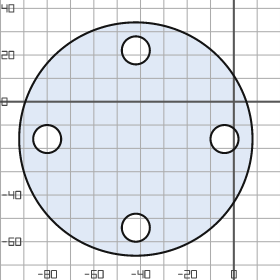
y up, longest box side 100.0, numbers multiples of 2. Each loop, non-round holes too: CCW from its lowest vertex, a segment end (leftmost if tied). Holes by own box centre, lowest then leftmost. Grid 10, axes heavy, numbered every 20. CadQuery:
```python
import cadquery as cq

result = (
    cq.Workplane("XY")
    .moveTo(-42.0, -16.0)
    .circle(50.0)
    .moveTo(-42.0, -54.0)
    .circle(6.0)
    .moveTo(-80.0, -16.0)
    .circle(6.0)
    .moveTo(-4.0, -16.0)
    .circle(6.0)
    .moveTo(-42.0, 22.0)
    .circle(6.0)
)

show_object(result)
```